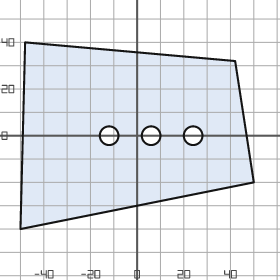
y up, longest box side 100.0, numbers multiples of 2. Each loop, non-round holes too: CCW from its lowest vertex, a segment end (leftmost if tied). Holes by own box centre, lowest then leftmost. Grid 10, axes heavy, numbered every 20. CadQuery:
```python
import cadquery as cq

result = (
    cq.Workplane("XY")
    .moveTo(-50.0, -40.0)
    .lineTo(50.0, -20.0)
    .lineTo(42.0, 32.0)
    .lineTo(-48.0, 40.0)
    .close()
    .moveTo(-12.0, 0.0)
    .circle(4.0)
    .moveTo(6.0, 0.0)
    .circle(4.0)
    .moveTo(24.0, 0.0)
    .circle(4.0)
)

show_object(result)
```